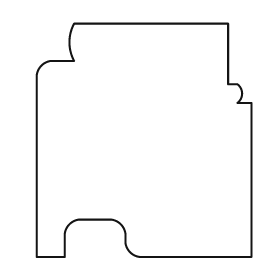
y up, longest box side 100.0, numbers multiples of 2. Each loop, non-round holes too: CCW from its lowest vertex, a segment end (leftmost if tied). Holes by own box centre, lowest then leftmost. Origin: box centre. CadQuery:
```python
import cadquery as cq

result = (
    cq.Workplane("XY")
    .moveTo(-46.0, -50.0)
    .lineTo(-34.0, -50.0)
    .lineTo(-34.0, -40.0)
    .threePointArc((-32.0, -36.0), (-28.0, -34.0))
    .lineTo(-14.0, -34.0)
    .threePointArc((-10.0, -36.0), (-8.0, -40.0))
    .lineTo(-8.0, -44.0)
    .threePointArc((-6.0, -48.0), (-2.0, -50.0))
    .lineTo(46.0, -50.0)
    .lineTo(46.0, 16.0)
    .lineTo(40.0, 16.0)
    .threePointArc((42.0, 20.0), (40.0, 24.0))
    .lineTo(36.0, 24.0)
    .lineTo(36.0, 50.0)
    .lineTo(-30.0, 50.0)
    .threePointArc((-32.0, 42.0), (-30.0, 34.0))
    .lineTo(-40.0, 34.0)
    .threePointArc((-44.0, 32.0), (-46.0, 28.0))
    .close()
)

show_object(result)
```